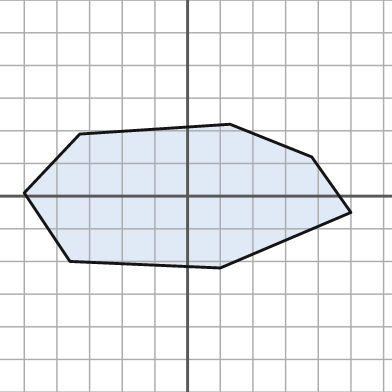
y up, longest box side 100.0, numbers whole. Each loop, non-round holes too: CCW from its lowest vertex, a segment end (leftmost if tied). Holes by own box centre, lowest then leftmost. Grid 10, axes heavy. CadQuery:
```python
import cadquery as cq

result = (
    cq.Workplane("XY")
    .moveTo(10.0, -22.0)
    .lineTo(50.0, -5.0)
    .lineTo(38.0, 12.0)
    .lineTo(13.0, 22.0)
    .lineTo(-33.0, 19.0)
    .lineTo(-50.0, 1.0)
    .lineTo(-36.0, -20.0)
    .close()
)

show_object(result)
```